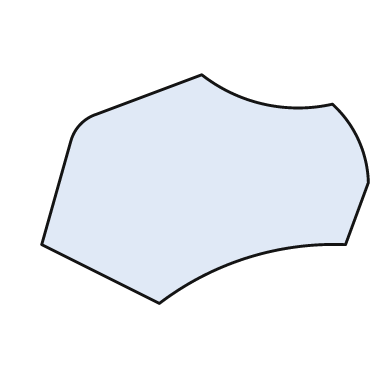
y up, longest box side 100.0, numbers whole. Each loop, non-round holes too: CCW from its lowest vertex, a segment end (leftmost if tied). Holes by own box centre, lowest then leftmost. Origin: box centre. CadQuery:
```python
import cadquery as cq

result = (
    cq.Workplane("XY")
    .moveTo(-14.0, -35.0)
    .threePointArc((13.0, -21.0), (43.0, -17.0))
    .lineTo(50.0, 2.0)
    .threePointArc((47.0, 15.0), (39.0, 26.0))
    .threePointArc((18.0, 26.0), (-1.0, 35.0))
    .lineTo(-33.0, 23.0)
    .threePointArc((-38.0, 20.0), (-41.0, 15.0))
    .lineTo(-50.0, -17.0)
    .close()
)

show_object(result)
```